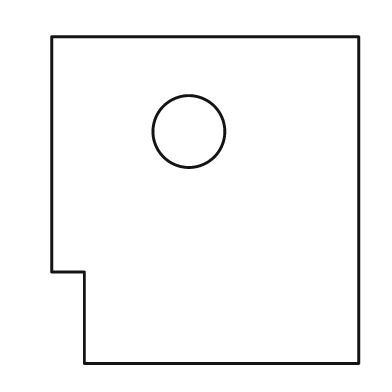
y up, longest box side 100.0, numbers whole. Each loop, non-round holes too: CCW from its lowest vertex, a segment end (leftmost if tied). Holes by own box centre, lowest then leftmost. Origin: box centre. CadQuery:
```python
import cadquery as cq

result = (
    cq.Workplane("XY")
    .moveTo(-37.0, -50.0)
    .lineTo(47.0, -50.0)
    .lineTo(47.0, 50.0)
    .lineTo(-47.0, 50.0)
    .lineTo(-47.0, -22.0)
    .lineTo(-37.0, -22.0)
    .close()
    .moveTo(-5.0, 21.0)
    .circle(11.0)
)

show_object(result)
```